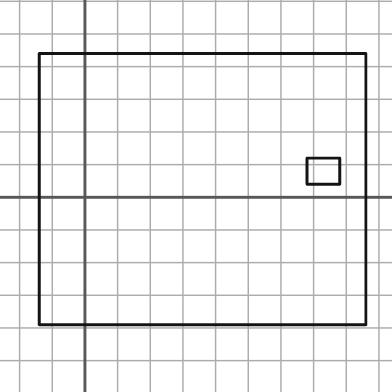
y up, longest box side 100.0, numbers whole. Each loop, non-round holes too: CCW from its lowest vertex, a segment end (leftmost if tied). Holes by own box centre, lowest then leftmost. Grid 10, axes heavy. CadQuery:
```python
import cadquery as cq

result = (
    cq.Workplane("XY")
    .moveTo(-14.0, -39.0)
    .lineTo(86.0, -39.0)
    .lineTo(86.0, 44.0)
    .lineTo(-14.0, 44.0)
    .close()
    .moveTo(68.0, 4.0)
    .lineTo(78.0, 4.0)
    .lineTo(78.0, 12.0)
    .lineTo(68.0, 12.0)
    .close()
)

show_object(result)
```